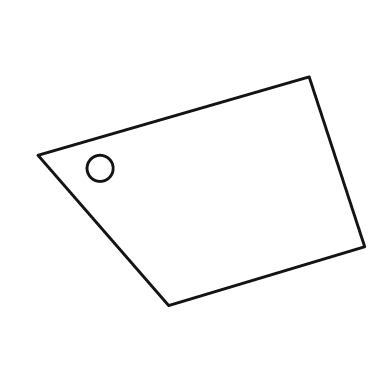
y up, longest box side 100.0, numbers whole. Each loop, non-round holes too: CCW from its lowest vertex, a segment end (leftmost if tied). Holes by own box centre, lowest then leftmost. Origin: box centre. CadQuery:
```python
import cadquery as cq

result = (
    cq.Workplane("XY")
    .moveTo(-10.0, -35.0)
    .lineTo(50.0, -17.0)
    .lineTo(33.0, 35.0)
    .lineTo(-50.0, 11.0)
    .close()
    .moveTo(-31.0, 7.0)
    .circle(4.0)
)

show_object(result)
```